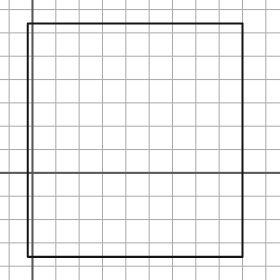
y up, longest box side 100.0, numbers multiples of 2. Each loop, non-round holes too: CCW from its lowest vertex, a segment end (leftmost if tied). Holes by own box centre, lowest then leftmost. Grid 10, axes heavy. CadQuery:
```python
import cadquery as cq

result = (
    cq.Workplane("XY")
    .moveTo(-2.0, -36.0)
    .lineTo(90.0, -36.0)
    .lineTo(90.0, 64.0)
    .lineTo(-2.0, 64.0)
    .close()
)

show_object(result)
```